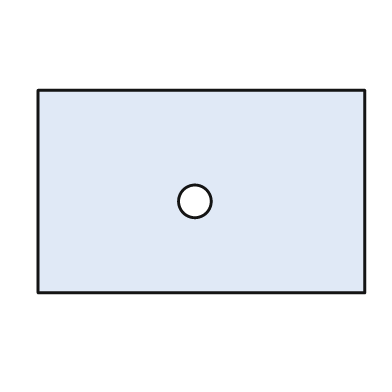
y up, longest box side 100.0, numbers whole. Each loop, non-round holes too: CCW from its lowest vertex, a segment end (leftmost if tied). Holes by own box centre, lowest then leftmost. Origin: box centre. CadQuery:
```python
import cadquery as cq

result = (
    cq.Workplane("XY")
    .moveTo(-50.0, -31.0)
    .lineTo(50.0, -31.0)
    .lineTo(50.0, 31.0)
    .lineTo(-50.0, 31.0)
    .close()
    .moveTo(-2.0, -3.0)
    .circle(5.0)
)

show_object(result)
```